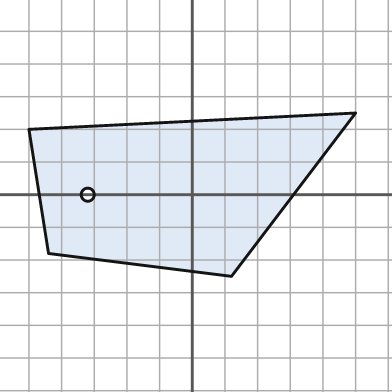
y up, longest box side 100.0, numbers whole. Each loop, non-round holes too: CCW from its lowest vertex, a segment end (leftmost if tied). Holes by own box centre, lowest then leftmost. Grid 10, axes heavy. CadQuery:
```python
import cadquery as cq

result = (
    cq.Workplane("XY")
    .moveTo(12.0, -25.0)
    .lineTo(50.0, 25.0)
    .lineTo(-50.0, 20.0)
    .lineTo(-44.0, -18.0)
    .close()
    .moveTo(-32.0, 0.0)
    .circle(2.0)
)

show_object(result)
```